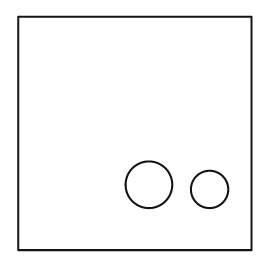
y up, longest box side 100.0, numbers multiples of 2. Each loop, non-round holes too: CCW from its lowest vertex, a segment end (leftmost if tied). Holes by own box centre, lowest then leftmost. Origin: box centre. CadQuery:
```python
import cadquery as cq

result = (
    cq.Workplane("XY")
    .moveTo(-50.0, -50.0)
    .lineTo(50.0, -50.0)
    .lineTo(50.0, 50.0)
    .lineTo(-50.0, 50.0)
    .close()
    .moveTo(32.0, -24.0)
    .circle(8.0)
    .moveTo(6.0, -22.0)
    .circle(10.0)
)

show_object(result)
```